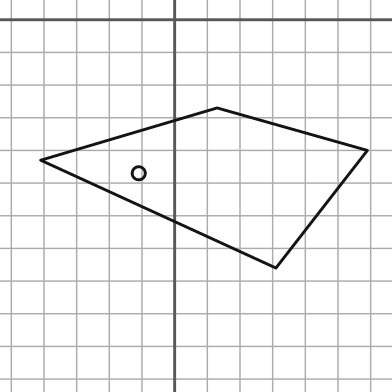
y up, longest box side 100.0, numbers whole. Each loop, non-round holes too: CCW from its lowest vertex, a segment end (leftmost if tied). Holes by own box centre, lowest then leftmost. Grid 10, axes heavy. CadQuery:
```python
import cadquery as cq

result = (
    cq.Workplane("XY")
    .moveTo(31.0, -76.0)
    .lineTo(59.0, -40.0)
    .lineTo(13.0, -27.0)
    .lineTo(-41.0, -43.0)
    .close()
    .moveTo(-11.0, -47.0)
    .circle(2.0)
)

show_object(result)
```